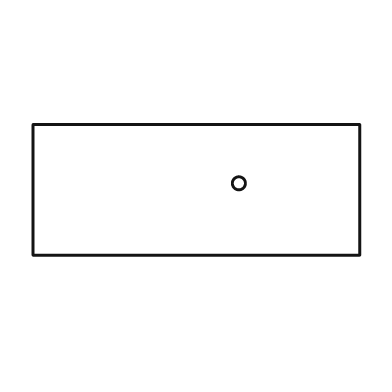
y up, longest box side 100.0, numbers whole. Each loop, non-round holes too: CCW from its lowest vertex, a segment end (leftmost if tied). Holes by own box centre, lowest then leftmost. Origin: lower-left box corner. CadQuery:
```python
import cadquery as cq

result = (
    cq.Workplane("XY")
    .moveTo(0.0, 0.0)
    .lineTo(100.0, 0.0)
    .lineTo(100.0, 40.0)
    .lineTo(0.0, 40.0)
    .close()
    .moveTo(63.0, 22.0)
    .circle(2.0)
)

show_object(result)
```